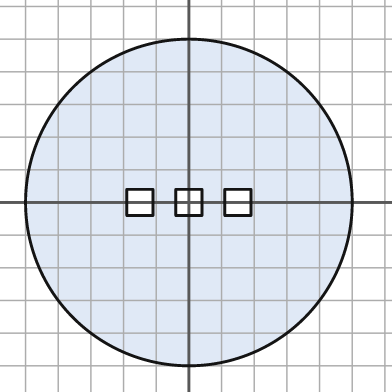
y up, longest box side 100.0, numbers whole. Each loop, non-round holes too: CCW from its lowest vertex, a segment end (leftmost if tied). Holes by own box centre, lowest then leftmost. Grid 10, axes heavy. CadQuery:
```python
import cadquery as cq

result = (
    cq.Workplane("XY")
    .moveTo(0.0, 0.0)
    .circle(50.0)
    .moveTo(-19.0, -4.0)
    .lineTo(-11.0, -4.0)
    .lineTo(-11.0, 4.0)
    .lineTo(-19.0, 4.0)
    .close()
    .moveTo(-4.0, -4.0)
    .lineTo(4.0, -4.0)
    .lineTo(4.0, 4.0)
    .lineTo(-4.0, 4.0)
    .close()
    .moveTo(11.0, -4.0)
    .lineTo(19.0, -4.0)
    .lineTo(19.0, 4.0)
    .lineTo(11.0, 4.0)
    .close()
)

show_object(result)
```